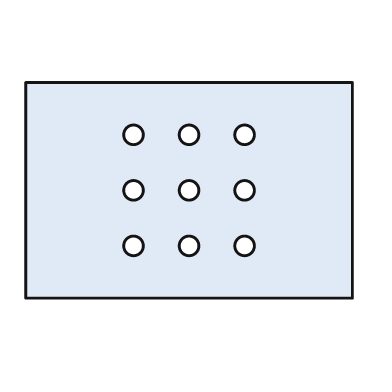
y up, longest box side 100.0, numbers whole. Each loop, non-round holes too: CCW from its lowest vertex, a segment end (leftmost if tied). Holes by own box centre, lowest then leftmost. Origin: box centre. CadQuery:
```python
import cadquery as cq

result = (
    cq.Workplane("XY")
    .moveTo(-50.0, -33.0)
    .lineTo(50.0, -33.0)
    .lineTo(50.0, 33.0)
    .lineTo(-50.0, 33.0)
    .close()
    .moveTo(-17.0, -17.0)
    .circle(3.0)
    .moveTo(0.0, -17.0)
    .circle(3.0)
    .moveTo(17.0, -17.0)
    .circle(3.0)
    .moveTo(-17.0, 0.0)
    .circle(3.0)
    .moveTo(0.0, 0.0)
    .circle(3.0)
    .moveTo(17.0, 0.0)
    .circle(3.0)
    .moveTo(-17.0, 17.0)
    .circle(3.0)
    .moveTo(0.0, 17.0)
    .circle(3.0)
    .moveTo(17.0, 17.0)
    .circle(3.0)
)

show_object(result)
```